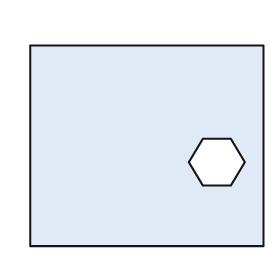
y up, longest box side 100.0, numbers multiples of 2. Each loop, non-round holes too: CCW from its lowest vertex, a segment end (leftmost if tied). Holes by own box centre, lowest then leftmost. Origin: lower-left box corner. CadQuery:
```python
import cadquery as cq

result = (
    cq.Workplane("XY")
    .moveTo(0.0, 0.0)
    .lineTo(100.0, 0.0)
    .lineTo(100.0, 86.0)
    .lineTo(0.0, 86.0)
    .close()
    .moveTo(74.0, 26.0)
    .lineTo(86.0, 26.0)
    .lineTo(92.0, 36.0)
    .lineTo(86.0, 46.0)
    .lineTo(74.0, 46.0)
    .lineTo(68.0, 36.0)
    .close()
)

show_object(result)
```